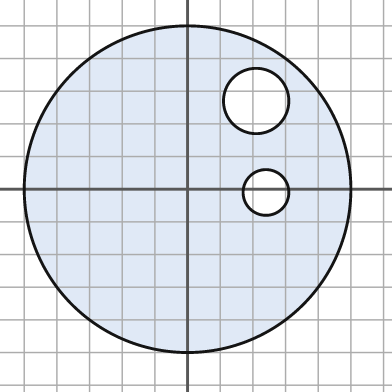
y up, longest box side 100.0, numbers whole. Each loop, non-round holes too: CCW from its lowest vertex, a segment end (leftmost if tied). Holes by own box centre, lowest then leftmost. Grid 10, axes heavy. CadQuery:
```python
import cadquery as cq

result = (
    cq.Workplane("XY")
    .moveTo(0.0, 0.0)
    .circle(50.0)
    .moveTo(24.0, -1.0)
    .circle(7.0)
    .moveTo(21.0, 27.0)
    .circle(10.0)
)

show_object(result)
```